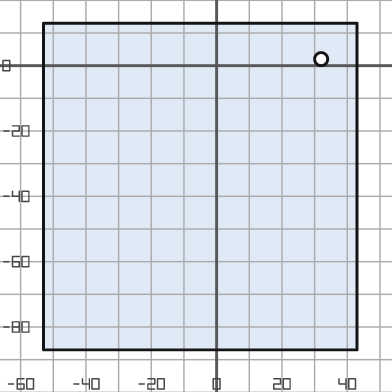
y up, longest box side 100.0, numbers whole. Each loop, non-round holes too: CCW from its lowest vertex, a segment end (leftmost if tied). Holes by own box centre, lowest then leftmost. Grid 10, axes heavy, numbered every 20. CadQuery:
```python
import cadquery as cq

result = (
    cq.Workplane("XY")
    .moveTo(-53.0, -87.0)
    .lineTo(43.0, -87.0)
    .lineTo(43.0, 13.0)
    .lineTo(-53.0, 13.0)
    .close()
    .moveTo(32.0, 2.0)
    .circle(2.0)
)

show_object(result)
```